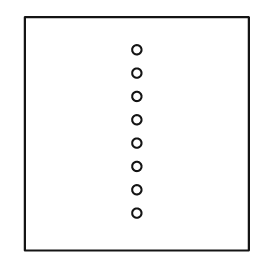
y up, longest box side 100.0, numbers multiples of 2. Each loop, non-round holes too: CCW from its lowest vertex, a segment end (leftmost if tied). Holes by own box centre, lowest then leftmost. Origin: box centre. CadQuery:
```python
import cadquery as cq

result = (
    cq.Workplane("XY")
    .moveTo(-48.0, -50.0)
    .lineTo(48.0, -50.0)
    .lineTo(48.0, 50.0)
    .lineTo(-48.0, 50.0)
    .close()
    .moveTo(0.0, -34.0)
    .circle(2.0)
    .moveTo(0.0, -24.0)
    .circle(2.0)
    .moveTo(0.0, -14.0)
    .circle(2.0)
    .moveTo(0.0, -4.0)
    .circle(2.0)
    .moveTo(0.0, 6.0)
    .circle(2.0)
    .moveTo(0.0, 16.0)
    .circle(2.0)
    .moveTo(0.0, 26.0)
    .circle(2.0)
    .moveTo(0.0, 36.0)
    .circle(2.0)
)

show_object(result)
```